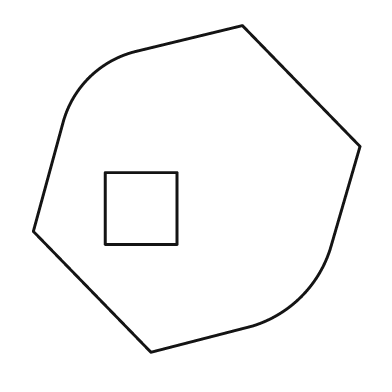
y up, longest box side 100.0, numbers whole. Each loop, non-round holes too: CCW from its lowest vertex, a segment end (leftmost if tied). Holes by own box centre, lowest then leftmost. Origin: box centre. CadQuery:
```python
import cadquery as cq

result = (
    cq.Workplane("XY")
    .moveTo(-14.0, -50.0)
    .lineTo(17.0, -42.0)
    .threePointArc((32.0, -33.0), (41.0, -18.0))
    .lineTo(50.0, 13.0)
    .lineTo(14.0, 50.0)
    .lineTo(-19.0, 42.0)
    .threePointArc((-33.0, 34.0), (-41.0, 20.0))
    .lineTo(-50.0, -13.0)
    .close()
    .moveTo(-28.0, -17.0)
    .lineTo(-6.0, -17.0)
    .lineTo(-6.0, 5.0)
    .lineTo(-28.0, 5.0)
    .close()
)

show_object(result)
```